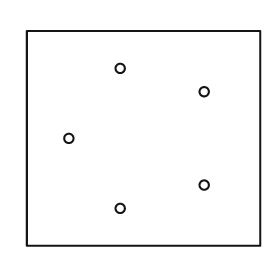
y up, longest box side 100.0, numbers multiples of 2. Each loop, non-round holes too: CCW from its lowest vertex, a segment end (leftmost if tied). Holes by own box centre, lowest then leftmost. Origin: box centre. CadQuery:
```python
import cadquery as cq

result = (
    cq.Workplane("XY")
    .moveTo(-50.0, -46.0)
    .lineTo(50.0, -46.0)
    .lineTo(50.0, 46.0)
    .lineTo(-50.0, 46.0)
    .close()
    .moveTo(-10.0, -30.0)
    .circle(2.0)
    .moveTo(26.0, -20.0)
    .circle(2.0)
    .moveTo(-32.0, 0.0)
    .circle(2.0)
    .moveTo(26.0, 20.0)
    .circle(2.0)
    .moveTo(-10.0, 30.0)
    .circle(2.0)
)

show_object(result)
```